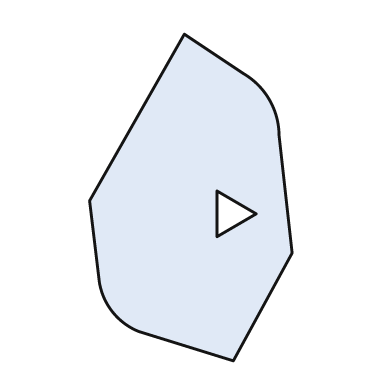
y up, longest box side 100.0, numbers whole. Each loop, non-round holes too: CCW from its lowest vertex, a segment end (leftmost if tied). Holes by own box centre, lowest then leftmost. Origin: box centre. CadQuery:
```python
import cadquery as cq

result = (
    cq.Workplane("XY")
    .moveTo(13.0, -50.0)
    .lineTo(31.0, -17.0)
    .lineTo(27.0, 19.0)
    .threePointArc((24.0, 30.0), (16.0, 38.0))
    .lineTo(-2.0, 50.0)
    .lineTo(-31.0, -1.0)
    .lineTo(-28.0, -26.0)
    .threePointArc((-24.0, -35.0), (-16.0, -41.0))
    .close()
    .moveTo(8.0, -12.0)
    .lineTo(20.0, -5.0)
    .lineTo(8.0, 2.0)
    .close()
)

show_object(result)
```